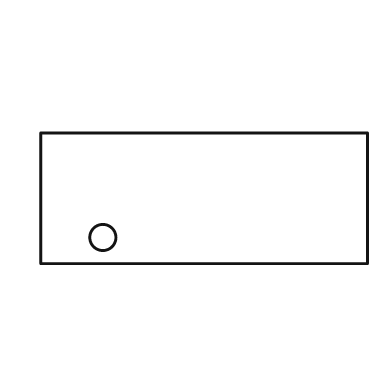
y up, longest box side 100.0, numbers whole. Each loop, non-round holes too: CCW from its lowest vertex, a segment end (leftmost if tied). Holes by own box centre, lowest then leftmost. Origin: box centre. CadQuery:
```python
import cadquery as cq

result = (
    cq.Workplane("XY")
    .moveTo(-50.0, -20.0)
    .lineTo(50.0, -20.0)
    .lineTo(50.0, 20.0)
    .lineTo(-50.0, 20.0)
    .close()
    .moveTo(-31.0, -12.0)
    .circle(4.0)
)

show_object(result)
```